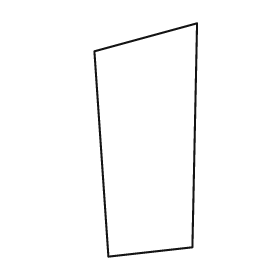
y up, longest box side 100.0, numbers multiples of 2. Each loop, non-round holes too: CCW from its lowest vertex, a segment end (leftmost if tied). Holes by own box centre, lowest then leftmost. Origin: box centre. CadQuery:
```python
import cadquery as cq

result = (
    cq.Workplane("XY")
    .moveTo(-16.0, -50.0)
    .lineTo(20.0, -46.0)
    .lineTo(22.0, 50.0)
    .lineTo(-22.0, 38.0)
    .close()
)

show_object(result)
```